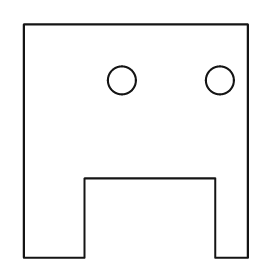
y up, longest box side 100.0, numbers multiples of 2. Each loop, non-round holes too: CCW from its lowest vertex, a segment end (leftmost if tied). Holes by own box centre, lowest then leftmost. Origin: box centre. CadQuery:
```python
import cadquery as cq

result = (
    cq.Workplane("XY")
    .moveTo(-48.0, -50.0)
    .lineTo(-22.0, -50.0)
    .lineTo(-22.0, -16.0)
    .lineTo(34.0, -16.0)
    .lineTo(34.0, -50.0)
    .lineTo(48.0, -50.0)
    .lineTo(48.0, 50.0)
    .lineTo(-48.0, 50.0)
    .close()
    .moveTo(-6.0, 26.0)
    .circle(6.0)
    .moveTo(36.0, 26.0)
    .circle(6.0)
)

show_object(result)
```